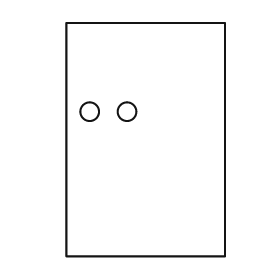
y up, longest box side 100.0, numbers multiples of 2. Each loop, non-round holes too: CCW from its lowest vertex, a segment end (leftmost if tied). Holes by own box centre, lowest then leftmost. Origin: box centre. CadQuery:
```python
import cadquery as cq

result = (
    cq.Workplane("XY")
    .moveTo(-34.0, -50.0)
    .lineTo(34.0, -50.0)
    .lineTo(34.0, 50.0)
    .lineTo(-34.0, 50.0)
    .close()
    .moveTo(-24.0, 12.0)
    .circle(4.0)
    .moveTo(-8.0, 12.0)
    .circle(4.0)
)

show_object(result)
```